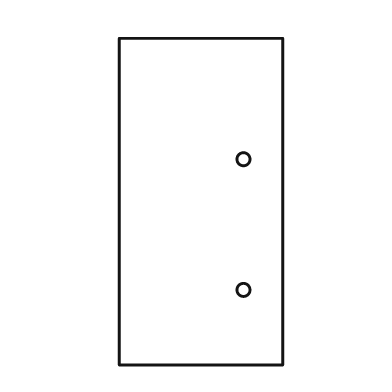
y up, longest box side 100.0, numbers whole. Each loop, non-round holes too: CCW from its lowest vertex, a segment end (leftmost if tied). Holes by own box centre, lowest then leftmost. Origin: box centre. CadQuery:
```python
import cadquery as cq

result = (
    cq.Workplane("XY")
    .moveTo(-25.0, -50.0)
    .lineTo(25.0, -50.0)
    .lineTo(25.0, 50.0)
    .lineTo(-25.0, 50.0)
    .close()
    .moveTo(13.0, -27.0)
    .circle(2.0)
    .moveTo(13.0, 13.0)
    .circle(2.0)
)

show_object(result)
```